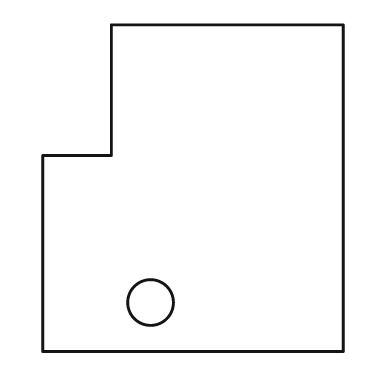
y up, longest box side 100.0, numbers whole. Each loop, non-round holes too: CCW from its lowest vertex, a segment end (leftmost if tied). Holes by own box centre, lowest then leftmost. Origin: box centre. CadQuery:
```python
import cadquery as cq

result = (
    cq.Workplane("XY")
    .moveTo(-46.0, -50.0)
    .lineTo(46.0, -50.0)
    .lineTo(46.0, 50.0)
    .lineTo(-25.0, 50.0)
    .lineTo(-25.0, 10.0)
    .lineTo(-46.0, 10.0)
    .close()
    .moveTo(-13.0, -35.0)
    .circle(7.0)
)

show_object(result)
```